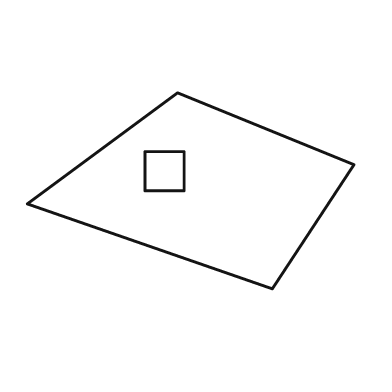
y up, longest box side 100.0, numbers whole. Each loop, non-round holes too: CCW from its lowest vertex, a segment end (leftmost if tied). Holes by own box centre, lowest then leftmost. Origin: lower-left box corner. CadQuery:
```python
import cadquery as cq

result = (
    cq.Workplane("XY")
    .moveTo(75.0, 0.0)
    .lineTo(100.0, 38.0)
    .lineTo(46.0, 60.0)
    .lineTo(0.0, 26.0)
    .close()
    .moveTo(36.0, 30.0)
    .lineTo(48.0, 30.0)
    .lineTo(48.0, 42.0)
    .lineTo(36.0, 42.0)
    .close()
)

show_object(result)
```